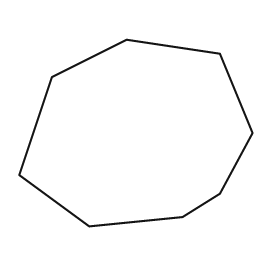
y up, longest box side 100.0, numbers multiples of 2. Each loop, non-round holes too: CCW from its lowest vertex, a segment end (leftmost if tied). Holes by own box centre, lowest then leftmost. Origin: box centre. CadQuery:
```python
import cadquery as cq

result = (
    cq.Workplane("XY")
    .moveTo(-20.0, -40.0)
    .lineTo(20.0, -36.0)
    .lineTo(36.0, -26.0)
    .lineTo(50.0, 0.0)
    .lineTo(36.0, 34.0)
    .lineTo(-4.0, 40.0)
    .lineTo(-36.0, 24.0)
    .lineTo(-50.0, -18.0)
    .close()
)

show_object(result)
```